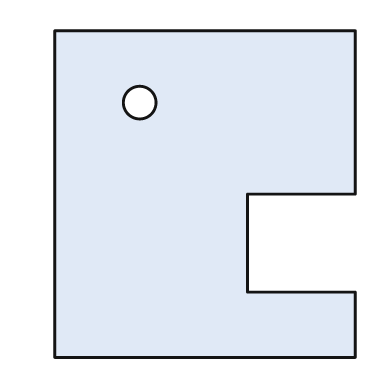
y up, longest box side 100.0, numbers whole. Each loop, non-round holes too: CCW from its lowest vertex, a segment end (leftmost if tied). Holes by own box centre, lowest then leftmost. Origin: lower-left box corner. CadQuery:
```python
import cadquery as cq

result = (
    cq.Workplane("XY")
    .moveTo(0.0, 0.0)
    .lineTo(92.0, 0.0)
    .lineTo(92.0, 20.0)
    .lineTo(59.0, 20.0)
    .lineTo(59.0, 50.0)
    .lineTo(92.0, 50.0)
    .lineTo(92.0, 100.0)
    .lineTo(0.0, 100.0)
    .close()
    .moveTo(26.0, 78.0)
    .circle(5.0)
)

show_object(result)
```